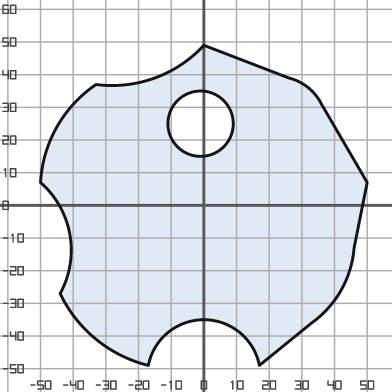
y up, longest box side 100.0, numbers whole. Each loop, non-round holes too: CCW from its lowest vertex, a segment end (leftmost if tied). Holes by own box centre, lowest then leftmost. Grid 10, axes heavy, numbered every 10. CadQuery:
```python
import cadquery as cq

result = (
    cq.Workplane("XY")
    .moveTo(-17.0, -49.0)
    .threePointArc((0.0, -35.0), (17.0, -49.0))
    .lineTo(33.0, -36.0)
    .threePointArc((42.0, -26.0), (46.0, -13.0))
    .lineTo(50.0, 7.0)
    .lineTo(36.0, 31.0)
    .threePointArc((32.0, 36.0), (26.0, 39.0))
    .lineTo(0.0, 49.0)
    .threePointArc((-15.0, 39.0), (-33.0, 37.0))
    .threePointArc((-45.0, 24.0), (-50.0, 7.0))
    .threePointArc((-41.0, -9.0), (-44.0, -27.0))
    .threePointArc((-33.0, -41.0), (-17.0, -49.0))
    .close()
    .moveTo(-1.0, 25.0)
    .circle(10.0)
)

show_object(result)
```